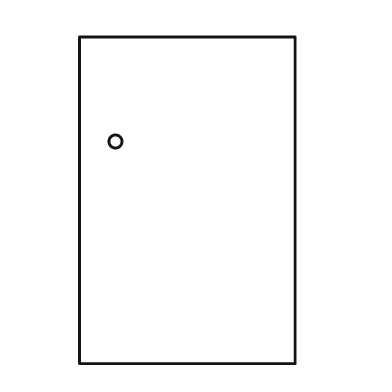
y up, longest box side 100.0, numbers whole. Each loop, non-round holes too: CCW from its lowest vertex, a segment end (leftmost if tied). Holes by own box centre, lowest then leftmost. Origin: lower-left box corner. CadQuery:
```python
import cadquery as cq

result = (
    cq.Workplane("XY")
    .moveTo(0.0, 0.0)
    .lineTo(66.0, 0.0)
    .lineTo(66.0, 100.0)
    .lineTo(0.0, 100.0)
    .close()
    .moveTo(11.0, 68.0)
    .circle(2.0)
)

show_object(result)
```